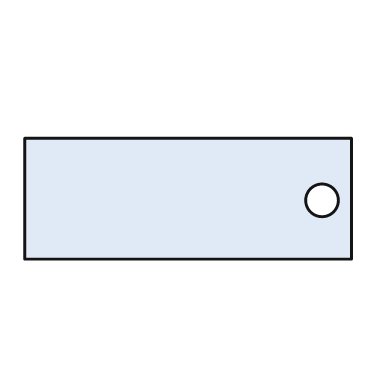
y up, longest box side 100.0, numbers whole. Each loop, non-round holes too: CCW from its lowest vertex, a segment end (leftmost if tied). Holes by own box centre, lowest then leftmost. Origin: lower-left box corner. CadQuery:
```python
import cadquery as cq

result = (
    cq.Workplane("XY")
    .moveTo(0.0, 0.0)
    .lineTo(100.0, 0.0)
    .lineTo(100.0, 37.0)
    .lineTo(0.0, 37.0)
    .close()
    .moveTo(91.0, 18.0)
    .circle(5.0)
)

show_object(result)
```